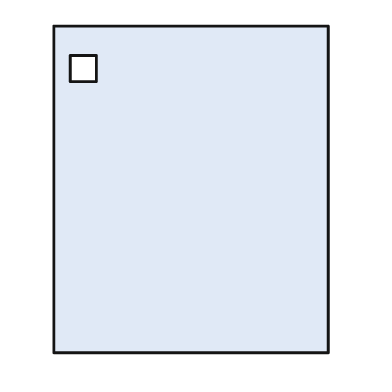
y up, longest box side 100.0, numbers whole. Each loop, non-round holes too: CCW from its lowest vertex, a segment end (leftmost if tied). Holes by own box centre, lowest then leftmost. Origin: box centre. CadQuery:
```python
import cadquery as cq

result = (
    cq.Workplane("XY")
    .moveTo(-42.0, -50.0)
    .lineTo(42.0, -50.0)
    .lineTo(42.0, 50.0)
    .lineTo(-42.0, 50.0)
    .close()
    .moveTo(-37.0, 33.0)
    .lineTo(-29.0, 33.0)
    .lineTo(-29.0, 41.0)
    .lineTo(-37.0, 41.0)
    .close()
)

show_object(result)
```